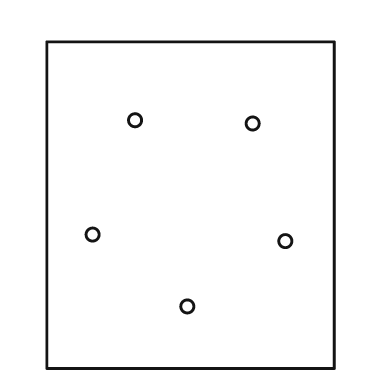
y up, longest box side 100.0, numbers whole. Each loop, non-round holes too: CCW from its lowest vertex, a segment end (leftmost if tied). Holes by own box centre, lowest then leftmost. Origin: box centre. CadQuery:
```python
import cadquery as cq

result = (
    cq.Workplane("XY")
    .moveTo(-44.0, -50.0)
    .lineTo(44.0, -50.0)
    .lineTo(44.0, 50.0)
    .lineTo(-44.0, 50.0)
    .close()
    .moveTo(-1.0, -31.0)
    .circle(2.0)
    .moveTo(29.0, -11.0)
    .circle(2.0)
    .moveTo(-30.0, -9.0)
    .circle(2.0)
    .moveTo(19.0, 25.0)
    .circle(2.0)
    .moveTo(-17.0, 26.0)
    .circle(2.0)
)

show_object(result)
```